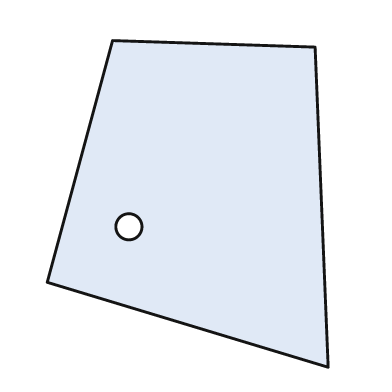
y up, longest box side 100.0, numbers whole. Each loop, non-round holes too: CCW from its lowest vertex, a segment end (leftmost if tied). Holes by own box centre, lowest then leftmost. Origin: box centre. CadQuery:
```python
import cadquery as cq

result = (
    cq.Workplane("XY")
    .moveTo(43.0, -50.0)
    .lineTo(39.0, 48.0)
    .lineTo(-23.0, 50.0)
    .lineTo(-43.0, -24.0)
    .close()
    .moveTo(-18.0, -7.0)
    .circle(4.0)
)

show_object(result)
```